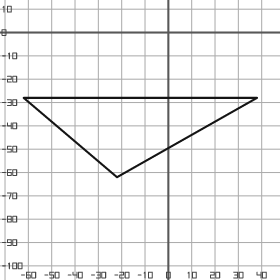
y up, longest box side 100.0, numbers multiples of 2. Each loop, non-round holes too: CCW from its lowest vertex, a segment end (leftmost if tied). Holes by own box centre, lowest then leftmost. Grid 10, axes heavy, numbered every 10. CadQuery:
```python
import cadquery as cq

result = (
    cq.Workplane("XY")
    .moveTo(-22.0, -62.0)
    .lineTo(38.0, -28.0)
    .lineTo(-62.0, -28.0)
    .close()
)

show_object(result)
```